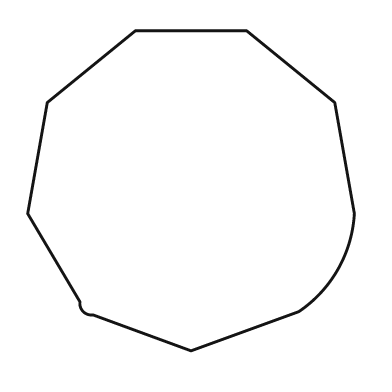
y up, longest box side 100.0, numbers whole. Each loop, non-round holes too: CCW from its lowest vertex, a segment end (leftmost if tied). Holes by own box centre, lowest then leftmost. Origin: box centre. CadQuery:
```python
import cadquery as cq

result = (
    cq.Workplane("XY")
    .moveTo(0.0, -49.0)
    .lineTo(33.0, -37.0)
    .threePointArc((45.0, -24.0), (50.0, -7.0))
    .lineTo(44.0, 27.0)
    .lineTo(17.0, 49.0)
    .lineTo(-17.0, 49.0)
    .lineTo(-44.0, 27.0)
    .lineTo(-50.0, -7.0)
    .lineTo(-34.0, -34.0)
    .threePointArc((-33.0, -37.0), (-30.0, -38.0))
    .close()
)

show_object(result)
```